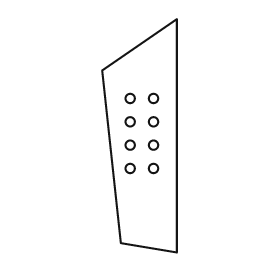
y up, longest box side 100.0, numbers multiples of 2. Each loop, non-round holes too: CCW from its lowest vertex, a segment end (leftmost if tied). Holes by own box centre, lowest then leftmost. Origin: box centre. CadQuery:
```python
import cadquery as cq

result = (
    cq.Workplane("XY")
    .moveTo(16.0, -50.0)
    .lineTo(16.0, 50.0)
    .lineTo(-16.0, 28.0)
    .lineTo(-8.0, -46.0)
    .close()
    .moveTo(-4.0, -14.0)
    .circle(2.0)
    .moveTo(6.0, -14.0)
    .circle(2.0)
    .moveTo(-4.0, -4.0)
    .circle(2.0)
    .moveTo(6.0, -4.0)
    .circle(2.0)
    .moveTo(-4.0, 6.0)
    .circle(2.0)
    .moveTo(6.0, 6.0)
    .circle(2.0)
    .moveTo(-4.0, 16.0)
    .circle(2.0)
    .moveTo(6.0, 16.0)
    .circle(2.0)
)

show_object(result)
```